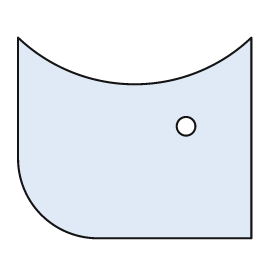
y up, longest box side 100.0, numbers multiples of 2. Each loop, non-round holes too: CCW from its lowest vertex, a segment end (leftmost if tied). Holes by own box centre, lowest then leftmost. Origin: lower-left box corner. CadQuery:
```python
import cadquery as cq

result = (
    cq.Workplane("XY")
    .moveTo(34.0, 0.0)
    .lineTo(100.0, 0.0)
    .lineTo(100.0, 86.0)
    .threePointArc((50.0, 66.0), (0.0, 86.0))
    .lineTo(0.0, 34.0)
    .threePointArc((10.0, 10.0), (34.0, 0.0))
    .close()
    .moveTo(72.0, 48.0)
    .circle(4.0)
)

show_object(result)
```